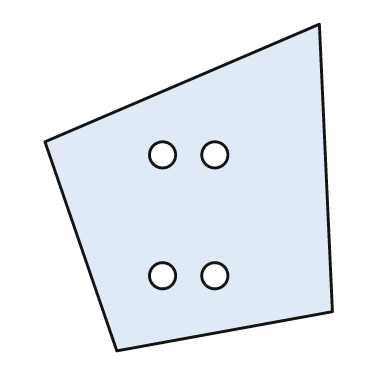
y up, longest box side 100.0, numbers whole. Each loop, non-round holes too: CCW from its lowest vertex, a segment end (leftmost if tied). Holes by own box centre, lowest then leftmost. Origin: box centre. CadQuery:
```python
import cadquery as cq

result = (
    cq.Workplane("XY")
    .moveTo(-22.0, -50.0)
    .lineTo(44.0, -38.0)
    .lineTo(40.0, 50.0)
    .lineTo(-44.0, 14.0)
    .close()
    .moveTo(-8.0, -27.0)
    .circle(4.0)
    .moveTo(8.0, -27.0)
    .circle(4.0)
    .moveTo(-8.0, 10.0)
    .circle(4.0)
    .moveTo(8.0, 10.0)
    .circle(4.0)
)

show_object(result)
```